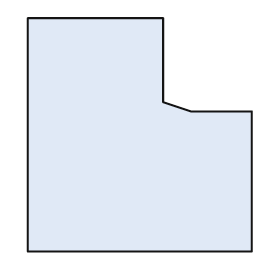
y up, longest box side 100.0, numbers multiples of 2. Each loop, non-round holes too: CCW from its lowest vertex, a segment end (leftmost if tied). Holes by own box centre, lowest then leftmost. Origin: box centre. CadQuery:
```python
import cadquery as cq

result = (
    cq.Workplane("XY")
    .moveTo(-48.0, -50.0)
    .lineTo(48.0, -50.0)
    .lineTo(48.0, 10.0)
    .lineTo(22.0, 10.0)
    .lineTo(10.0, 14.0)
    .lineTo(10.0, 50.0)
    .lineTo(-48.0, 50.0)
    .close()
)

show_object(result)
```